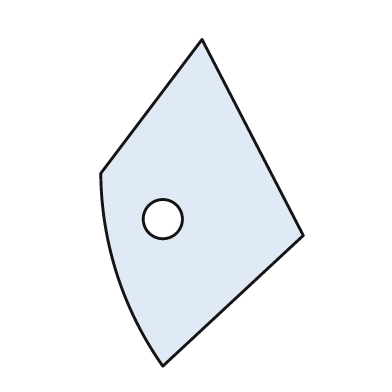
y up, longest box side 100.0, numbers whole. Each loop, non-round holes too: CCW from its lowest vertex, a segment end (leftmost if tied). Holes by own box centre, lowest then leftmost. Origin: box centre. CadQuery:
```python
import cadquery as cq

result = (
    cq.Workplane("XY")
    .moveTo(-12.0, -50.0)
    .lineTo(31.0, -10.0)
    .lineTo(0.0, 50.0)
    .lineTo(-31.0, 9.0)
    .threePointArc((-26.0, -22.0), (-12.0, -50.0))
    .close()
    .moveTo(-12.0, -5.0)
    .circle(6.0)
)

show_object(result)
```